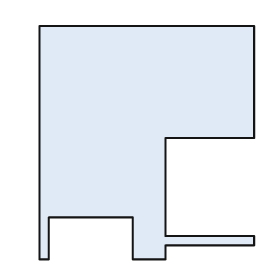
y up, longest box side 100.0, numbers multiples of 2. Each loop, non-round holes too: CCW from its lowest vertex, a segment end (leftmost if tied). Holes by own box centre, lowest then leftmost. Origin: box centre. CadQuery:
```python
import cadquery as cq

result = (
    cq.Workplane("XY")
    .moveTo(-46.0, -50.0)
    .lineTo(-42.0, -50.0)
    .lineTo(-42.0, -32.0)
    .lineTo(-6.0, -32.0)
    .lineTo(-6.0, -50.0)
    .lineTo(8.0, -50.0)
    .lineTo(8.0, -44.0)
    .lineTo(46.0, -44.0)
    .lineTo(46.0, -40.0)
    .lineTo(8.0, -40.0)
    .lineTo(8.0, 2.0)
    .lineTo(46.0, 2.0)
    .lineTo(46.0, 50.0)
    .lineTo(-46.0, 50.0)
    .close()
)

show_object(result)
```